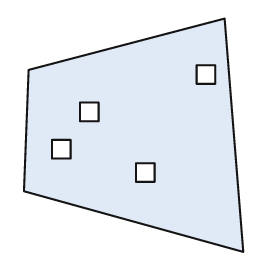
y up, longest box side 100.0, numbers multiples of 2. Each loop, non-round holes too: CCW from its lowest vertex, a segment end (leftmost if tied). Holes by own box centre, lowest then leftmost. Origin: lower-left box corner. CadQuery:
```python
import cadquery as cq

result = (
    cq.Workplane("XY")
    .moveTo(94.0, 0.0)
    .lineTo(86.0, 100.0)
    .lineTo(2.0, 78.0)
    .lineTo(0.0, 26.0)
    .close()
    .moveTo(48.0, 30.0)
    .lineTo(56.0, 30.0)
    .lineTo(56.0, 38.0)
    .lineTo(48.0, 38.0)
    .close()
    .moveTo(12.0, 40.0)
    .lineTo(20.0, 40.0)
    .lineTo(20.0, 48.0)
    .lineTo(12.0, 48.0)
    .close()
    .moveTo(24.0, 56.0)
    .lineTo(32.0, 56.0)
    .lineTo(32.0, 64.0)
    .lineTo(24.0, 64.0)
    .close()
    .moveTo(74.0, 72.0)
    .lineTo(82.0, 72.0)
    .lineTo(82.0, 80.0)
    .lineTo(74.0, 80.0)
    .close()
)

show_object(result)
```